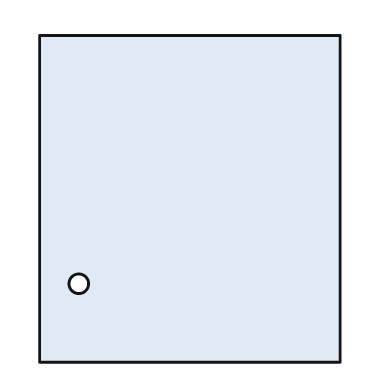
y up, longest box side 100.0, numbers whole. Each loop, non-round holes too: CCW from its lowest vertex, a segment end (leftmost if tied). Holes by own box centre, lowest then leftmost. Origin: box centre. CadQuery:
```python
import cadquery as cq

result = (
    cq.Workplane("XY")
    .moveTo(-46.0, -50.0)
    .lineTo(46.0, -50.0)
    .lineTo(46.0, 50.0)
    .lineTo(-46.0, 50.0)
    .close()
    .moveTo(-34.0, -26.0)
    .circle(3.0)
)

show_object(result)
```